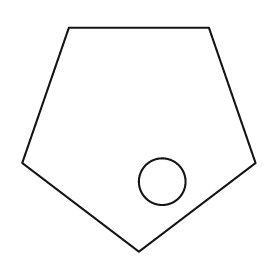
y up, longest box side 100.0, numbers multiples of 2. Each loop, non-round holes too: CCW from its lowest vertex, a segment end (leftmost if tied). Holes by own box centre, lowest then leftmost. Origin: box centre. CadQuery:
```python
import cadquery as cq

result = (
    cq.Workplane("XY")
    .moveTo(0.0, -48.0)
    .lineTo(50.0, -10.0)
    .lineTo(30.0, 48.0)
    .lineTo(-30.0, 48.0)
    .lineTo(-50.0, -10.0)
    .close()
    .moveTo(10.0, -18.0)
    .circle(10.0)
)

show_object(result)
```